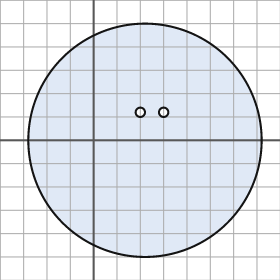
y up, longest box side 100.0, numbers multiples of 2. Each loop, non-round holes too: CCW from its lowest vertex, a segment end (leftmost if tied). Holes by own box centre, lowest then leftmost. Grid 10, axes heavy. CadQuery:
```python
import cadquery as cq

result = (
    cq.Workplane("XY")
    .moveTo(22.0, 0.0)
    .circle(50.0)
    .moveTo(20.0, 12.0)
    .circle(2.0)
    .moveTo(30.0, 12.0)
    .circle(2.0)
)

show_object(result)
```